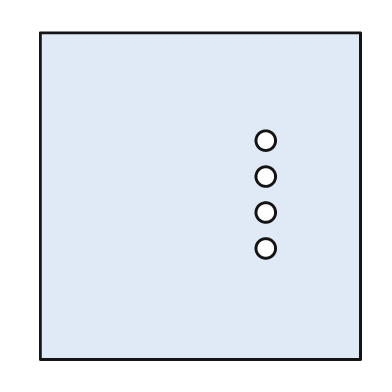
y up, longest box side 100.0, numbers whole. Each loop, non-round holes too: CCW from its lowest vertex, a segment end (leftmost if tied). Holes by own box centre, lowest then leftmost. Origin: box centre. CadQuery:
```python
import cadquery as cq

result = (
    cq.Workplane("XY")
    .moveTo(-49.0, -50.0)
    .lineTo(49.0, -50.0)
    .lineTo(49.0, 50.0)
    .lineTo(-49.0, 50.0)
    .close()
    .moveTo(20.0, -16.0)
    .circle(3.0)
    .moveTo(20.0, -5.0)
    .circle(3.0)
    .moveTo(20.0, 6.0)
    .circle(3.0)
    .moveTo(20.0, 17.0)
    .circle(3.0)
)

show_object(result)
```